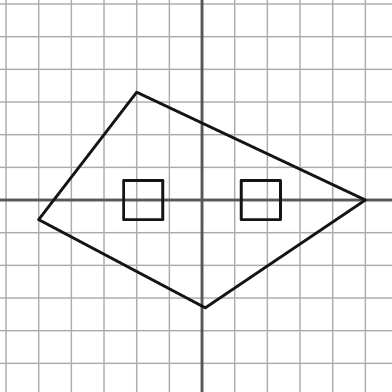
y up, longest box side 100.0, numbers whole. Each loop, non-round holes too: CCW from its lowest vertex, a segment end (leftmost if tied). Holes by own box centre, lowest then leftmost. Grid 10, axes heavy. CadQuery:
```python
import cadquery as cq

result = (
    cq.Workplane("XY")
    .moveTo(1.0, -33.0)
    .lineTo(50.0, 0.0)
    .lineTo(-20.0, 33.0)
    .lineTo(-50.0, -6.0)
    .close()
    .moveTo(-24.0, -6.0)
    .lineTo(-12.0, -6.0)
    .lineTo(-12.0, 6.0)
    .lineTo(-24.0, 6.0)
    .close()
    .moveTo(12.0, -6.0)
    .lineTo(24.0, -6.0)
    .lineTo(24.0, 6.0)
    .lineTo(12.0, 6.0)
    .close()
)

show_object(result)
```